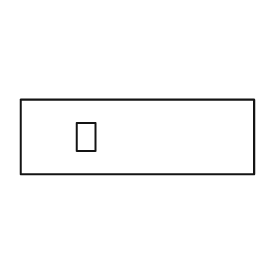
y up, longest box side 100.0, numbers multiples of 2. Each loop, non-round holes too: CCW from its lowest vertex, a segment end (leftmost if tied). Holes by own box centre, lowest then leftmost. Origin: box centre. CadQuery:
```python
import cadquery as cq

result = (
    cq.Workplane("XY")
    .moveTo(-50.0, -16.0)
    .lineTo(50.0, -16.0)
    .lineTo(50.0, 16.0)
    .lineTo(-50.0, 16.0)
    .close()
    .moveTo(-26.0, -6.0)
    .lineTo(-18.0, -6.0)
    .lineTo(-18.0, 6.0)
    .lineTo(-26.0, 6.0)
    .close()
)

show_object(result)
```